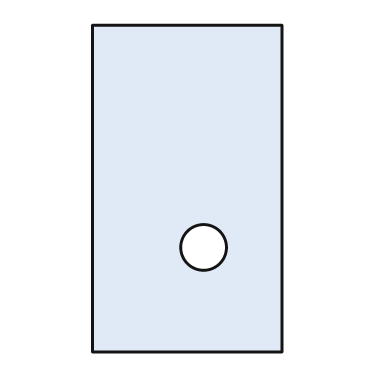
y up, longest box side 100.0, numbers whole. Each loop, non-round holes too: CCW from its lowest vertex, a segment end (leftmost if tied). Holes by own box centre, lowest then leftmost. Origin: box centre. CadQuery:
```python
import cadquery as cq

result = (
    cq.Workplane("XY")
    .moveTo(-29.0, -50.0)
    .lineTo(29.0, -50.0)
    .lineTo(29.0, 50.0)
    .lineTo(-29.0, 50.0)
    .close()
    .moveTo(5.0, -18.0)
    .circle(7.0)
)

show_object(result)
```